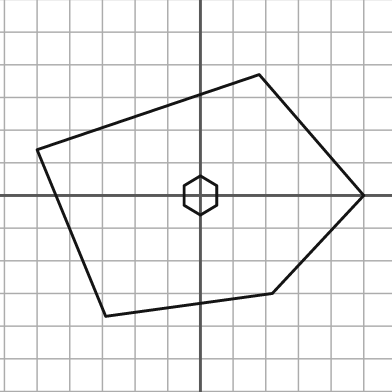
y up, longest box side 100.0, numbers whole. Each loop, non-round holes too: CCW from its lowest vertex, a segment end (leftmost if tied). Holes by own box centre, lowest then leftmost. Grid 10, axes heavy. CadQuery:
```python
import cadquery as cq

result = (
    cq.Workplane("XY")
    .moveTo(-29.0, -37.0)
    .lineTo(22.0, -30.0)
    .lineTo(50.0, 0.0)
    .lineTo(18.0, 37.0)
    .lineTo(-50.0, 14.0)
    .close()
    .moveTo(0.0, -6.0)
    .lineTo(5.0, -3.0)
    .lineTo(5.0, 3.0)
    .lineTo(0.0, 6.0)
    .lineTo(-5.0, 3.0)
    .lineTo(-5.0, -3.0)
    .close()
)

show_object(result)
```